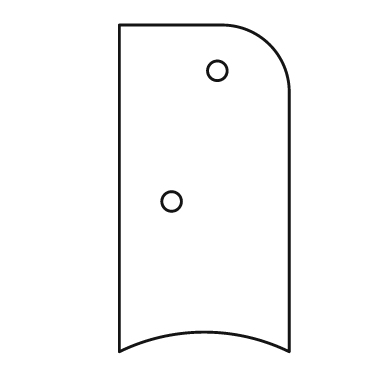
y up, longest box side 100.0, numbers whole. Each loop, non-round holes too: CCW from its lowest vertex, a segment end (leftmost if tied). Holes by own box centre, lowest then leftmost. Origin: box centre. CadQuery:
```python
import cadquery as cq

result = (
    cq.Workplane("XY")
    .moveTo(-26.0, -50.0)
    .threePointArc((0.0, -44.0), (26.0, -50.0))
    .lineTo(26.0, 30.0)
    .threePointArc((20.0, 44.0), (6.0, 50.0))
    .lineTo(-26.0, 50.0)
    .close()
    .moveTo(-10.0, -4.0)
    .circle(3.0)
    .moveTo(4.0, 36.0)
    .circle(3.0)
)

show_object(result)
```